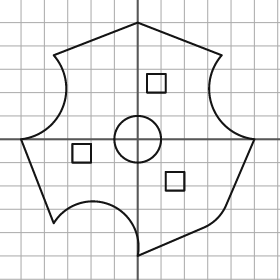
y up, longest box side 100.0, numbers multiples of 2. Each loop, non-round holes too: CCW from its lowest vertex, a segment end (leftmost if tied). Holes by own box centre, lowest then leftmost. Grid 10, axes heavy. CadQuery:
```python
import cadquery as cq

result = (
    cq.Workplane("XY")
    .moveTo(0.0, -50.0)
    .lineTo(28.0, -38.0)
    .threePointArc((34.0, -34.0), (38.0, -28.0))
    .lineTo(50.0, 0.0)
    .threePointArc((32.0, 14.0), (36.0, 36.0))
    .lineTo(0.0, 50.0)
    .lineTo(-36.0, 36.0)
    .threePointArc((-32.0, 14.0), (-50.0, 0.0))
    .lineTo(-36.0, -36.0)
    .threePointArc((-12.0, -28.0), (0.0, -50.0))
    .close()
    .moveTo(12.0, -22.0)
    .lineTo(20.0, -22.0)
    .lineTo(20.0, -14.0)
    .lineTo(12.0, -14.0)
    .close()
    .moveTo(-28.0, -10.0)
    .lineTo(-20.0, -10.0)
    .lineTo(-20.0, -2.0)
    .lineTo(-28.0, -2.0)
    .close()
    .moveTo(0.0, 0.0)
    .circle(10.0)
    .moveTo(4.0, 20.0)
    .lineTo(12.0, 20.0)
    .lineTo(12.0, 28.0)
    .lineTo(4.0, 28.0)
    .close()
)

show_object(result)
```